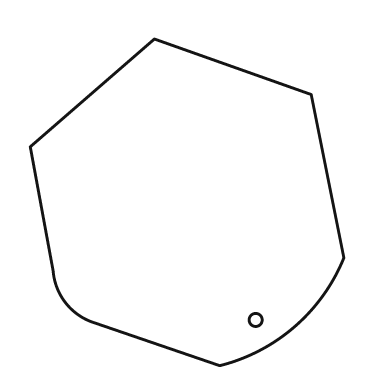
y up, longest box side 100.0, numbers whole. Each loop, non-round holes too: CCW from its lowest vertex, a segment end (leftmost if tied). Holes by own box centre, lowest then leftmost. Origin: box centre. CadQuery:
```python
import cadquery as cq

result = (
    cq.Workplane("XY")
    .moveTo(10.0, -50.0)
    .threePointArc((33.0, -38.0), (48.0, -17.0))
    .lineTo(38.0, 33.0)
    .lineTo(-10.0, 50.0)
    .lineTo(-48.0, 17.0)
    .lineTo(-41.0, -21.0)
    .threePointArc((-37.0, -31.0), (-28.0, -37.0))
    .close()
    .moveTo(21.0, -36.0)
    .circle(2.0)
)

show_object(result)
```